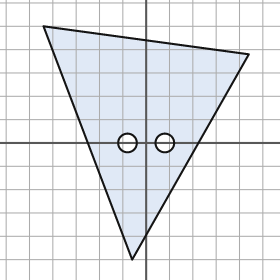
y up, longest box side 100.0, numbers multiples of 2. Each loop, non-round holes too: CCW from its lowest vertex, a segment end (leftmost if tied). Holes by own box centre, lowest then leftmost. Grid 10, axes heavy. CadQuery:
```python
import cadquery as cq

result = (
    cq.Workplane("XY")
    .moveTo(-6.0, -50.0)
    .lineTo(44.0, 38.0)
    .lineTo(-44.0, 50.0)
    .close()
    .moveTo(-8.0, 0.0)
    .circle(4.0)
    .moveTo(8.0, 0.0)
    .circle(4.0)
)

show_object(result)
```